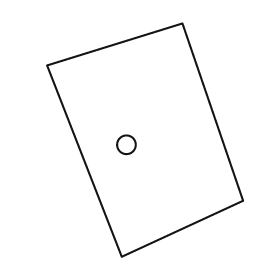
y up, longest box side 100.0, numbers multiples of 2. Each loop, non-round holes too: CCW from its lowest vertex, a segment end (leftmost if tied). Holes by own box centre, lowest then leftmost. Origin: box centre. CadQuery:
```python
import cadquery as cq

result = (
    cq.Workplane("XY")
    .moveTo(-10.0, -50.0)
    .lineTo(42.0, -26.0)
    .lineTo(16.0, 50.0)
    .lineTo(-42.0, 32.0)
    .close()
    .moveTo(-8.0, -2.0)
    .circle(4.0)
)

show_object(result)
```